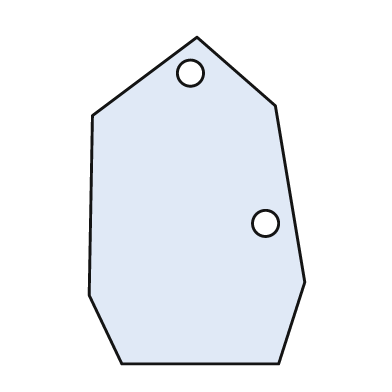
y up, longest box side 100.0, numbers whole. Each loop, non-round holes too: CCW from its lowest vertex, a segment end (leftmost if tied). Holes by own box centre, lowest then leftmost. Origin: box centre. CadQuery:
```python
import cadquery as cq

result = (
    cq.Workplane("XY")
    .moveTo(-23.0, -50.0)
    .lineTo(25.0, -50.0)
    .lineTo(33.0, -25.0)
    .lineTo(24.0, 29.0)
    .lineTo(0.0, 50.0)
    .lineTo(-32.0, 26.0)
    .lineTo(-33.0, -29.0)
    .close()
    .moveTo(21.0, -7.0)
    .circle(4.0)
    .moveTo(-2.0, 39.0)
    .circle(4.0)
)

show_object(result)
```